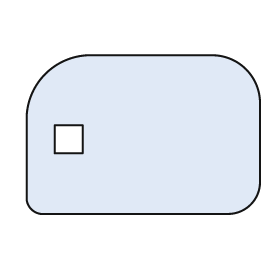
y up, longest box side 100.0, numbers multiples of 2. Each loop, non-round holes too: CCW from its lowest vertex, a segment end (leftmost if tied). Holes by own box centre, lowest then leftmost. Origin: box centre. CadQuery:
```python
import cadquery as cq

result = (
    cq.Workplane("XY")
    .moveTo(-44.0, -34.0)
    .lineTo(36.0, -34.0)
    .threePointArc((46.0, -30.0), (50.0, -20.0))
    .lineTo(50.0, 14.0)
    .threePointArc((44.0, 28.0), (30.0, 34.0))
    .lineTo(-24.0, 34.0)
    .threePointArc((-42.0, 26.0), (-50.0, 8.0))
    .lineTo(-50.0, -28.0)
    .threePointArc((-48.0, -32.0), (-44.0, -34.0))
    .close()
    .moveTo(-38.0, -8.0)
    .lineTo(-26.0, -8.0)
    .lineTo(-26.0, 4.0)
    .lineTo(-38.0, 4.0)
    .close()
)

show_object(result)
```